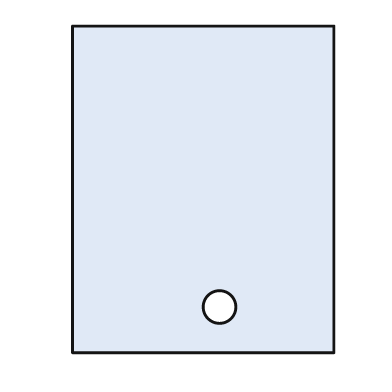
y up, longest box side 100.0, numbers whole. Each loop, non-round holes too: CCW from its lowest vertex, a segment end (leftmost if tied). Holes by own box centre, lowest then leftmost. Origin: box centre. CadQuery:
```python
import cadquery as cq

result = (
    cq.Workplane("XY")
    .moveTo(-40.0, -50.0)
    .lineTo(40.0, -50.0)
    .lineTo(40.0, 50.0)
    .lineTo(-40.0, 50.0)
    .close()
    .moveTo(5.0, -36.0)
    .circle(5.0)
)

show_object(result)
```